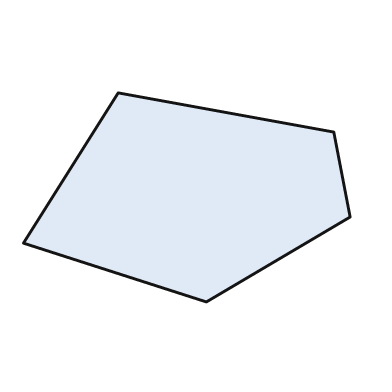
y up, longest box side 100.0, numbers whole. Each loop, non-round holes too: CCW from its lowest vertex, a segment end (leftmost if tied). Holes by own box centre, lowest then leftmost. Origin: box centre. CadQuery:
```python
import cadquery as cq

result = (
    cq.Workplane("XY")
    .moveTo(6.0, -32.0)
    .lineTo(50.0, -6.0)
    .lineTo(45.0, 20.0)
    .lineTo(-21.0, 32.0)
    .lineTo(-50.0, -14.0)
    .close()
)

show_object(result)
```